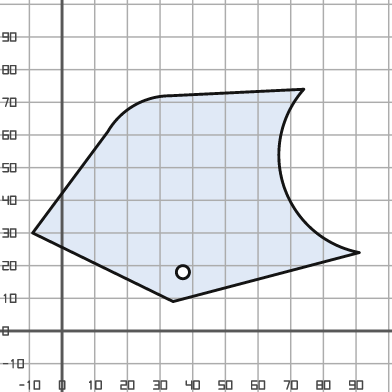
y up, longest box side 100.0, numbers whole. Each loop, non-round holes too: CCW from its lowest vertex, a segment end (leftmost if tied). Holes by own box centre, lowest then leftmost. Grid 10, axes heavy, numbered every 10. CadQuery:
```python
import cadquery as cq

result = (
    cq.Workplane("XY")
    .moveTo(34.0, 9.0)
    .lineTo(91.0, 24.0)
    .threePointArc((68.0, 44.0), (74.0, 74.0))
    .lineTo(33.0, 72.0)
    .threePointArc((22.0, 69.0), (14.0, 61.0))
    .lineTo(-9.0, 30.0)
    .close()
    .moveTo(37.0, 18.0)
    .circle(2.0)
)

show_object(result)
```